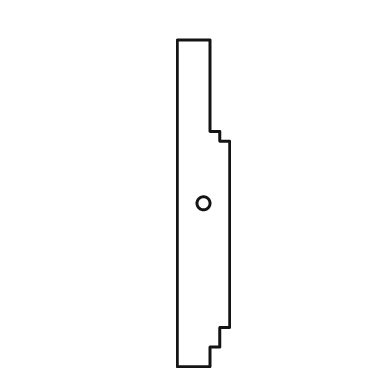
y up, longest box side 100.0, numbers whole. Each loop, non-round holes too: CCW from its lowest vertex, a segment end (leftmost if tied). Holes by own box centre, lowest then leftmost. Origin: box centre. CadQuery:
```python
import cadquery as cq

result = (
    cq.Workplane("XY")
    .moveTo(-8.0, -50.0)
    .lineTo(2.0, -50.0)
    .lineTo(2.0, -44.0)
    .lineTo(5.0, -44.0)
    .lineTo(5.0, -38.0)
    .lineTo(8.0, -38.0)
    .lineTo(8.0, 19.0)
    .lineTo(5.0, 19.0)
    .lineTo(5.0, 22.0)
    .lineTo(2.0, 22.0)
    .lineTo(2.0, 50.0)
    .lineTo(-8.0, 50.0)
    .close()
    .moveTo(0.0, 0.0)
    .circle(2.0)
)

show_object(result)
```